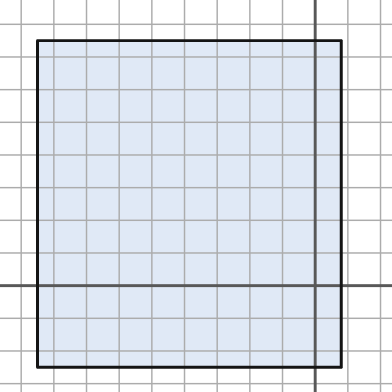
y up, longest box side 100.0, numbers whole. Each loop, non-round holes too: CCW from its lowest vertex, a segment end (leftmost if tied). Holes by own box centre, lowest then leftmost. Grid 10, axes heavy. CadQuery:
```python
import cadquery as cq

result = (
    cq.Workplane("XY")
    .moveTo(-85.0, -25.0)
    .lineTo(8.0, -25.0)
    .lineTo(8.0, 75.0)
    .lineTo(-85.0, 75.0)
    .close()
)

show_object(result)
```